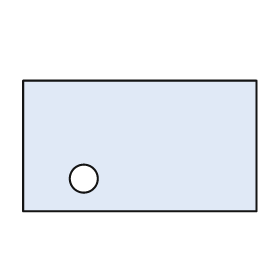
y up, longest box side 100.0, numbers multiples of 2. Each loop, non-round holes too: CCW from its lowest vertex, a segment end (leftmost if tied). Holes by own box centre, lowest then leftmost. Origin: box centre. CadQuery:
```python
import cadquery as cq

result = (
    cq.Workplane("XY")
    .moveTo(-50.0, -28.0)
    .lineTo(50.0, -28.0)
    .lineTo(50.0, 28.0)
    .lineTo(-50.0, 28.0)
    .close()
    .moveTo(-24.0, -14.0)
    .circle(6.0)
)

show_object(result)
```